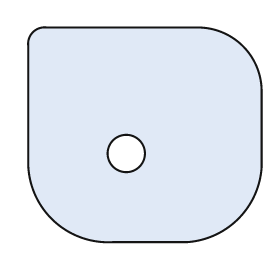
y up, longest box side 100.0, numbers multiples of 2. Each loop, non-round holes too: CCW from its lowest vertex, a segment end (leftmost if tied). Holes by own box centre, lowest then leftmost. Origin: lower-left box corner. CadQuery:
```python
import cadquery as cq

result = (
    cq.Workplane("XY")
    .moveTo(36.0, 0.0)
    .lineTo(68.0, 0.0)
    .threePointArc((90.0, 10.0), (100.0, 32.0))
    .lineTo(100.0, 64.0)
    .threePointArc((92.0, 84.0), (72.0, 92.0))
    .lineTo(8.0, 92.0)
    .threePointArc((2.0, 90.0), (0.0, 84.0))
    .lineTo(0.0, 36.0)
    .threePointArc((10.0, 10.0), (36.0, 0.0))
    .close()
    .moveTo(42.0, 38.0)
    .circle(8.0)
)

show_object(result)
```